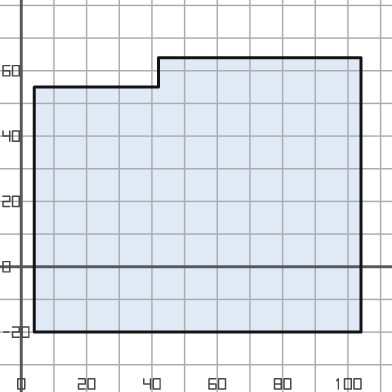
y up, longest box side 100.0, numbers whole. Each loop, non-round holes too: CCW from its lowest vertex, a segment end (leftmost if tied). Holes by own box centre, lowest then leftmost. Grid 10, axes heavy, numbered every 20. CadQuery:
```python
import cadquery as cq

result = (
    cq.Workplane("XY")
    .moveTo(4.0, -20.0)
    .lineTo(104.0, -20.0)
    .lineTo(104.0, 64.0)
    .lineTo(42.0, 64.0)
    .lineTo(42.0, 55.0)
    .lineTo(4.0, 55.0)
    .close()
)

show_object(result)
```